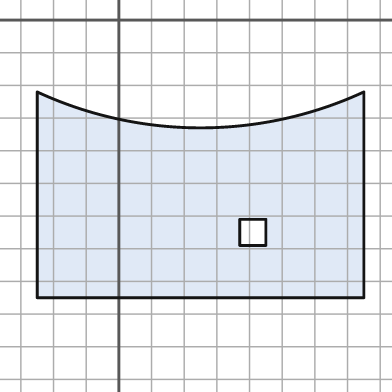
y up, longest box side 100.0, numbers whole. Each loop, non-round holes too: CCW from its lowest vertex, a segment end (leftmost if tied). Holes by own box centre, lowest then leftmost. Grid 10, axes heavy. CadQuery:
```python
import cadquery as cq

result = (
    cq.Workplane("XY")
    .moveTo(-25.0, -85.0)
    .lineTo(75.0, -85.0)
    .lineTo(75.0, -22.0)
    .threePointArc((25.0, -33.0), (-25.0, -22.0))
    .close()
    .moveTo(37.0, -69.0)
    .lineTo(45.0, -69.0)
    .lineTo(45.0, -61.0)
    .lineTo(37.0, -61.0)
    .close()
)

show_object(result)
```